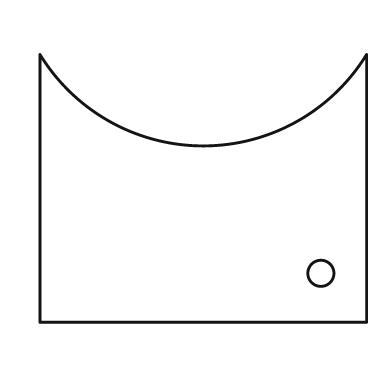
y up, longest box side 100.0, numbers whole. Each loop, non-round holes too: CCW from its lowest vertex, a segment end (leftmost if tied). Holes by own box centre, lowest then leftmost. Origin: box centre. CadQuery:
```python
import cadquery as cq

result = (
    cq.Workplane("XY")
    .moveTo(-50.0, -41.0)
    .lineTo(50.0, -41.0)
    .lineTo(50.0, 41.0)
    .threePointArc((0.0, 13.0), (-50.0, 41.0))
    .close()
    .moveTo(36.0, -26.0)
    .circle(4.0)
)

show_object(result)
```